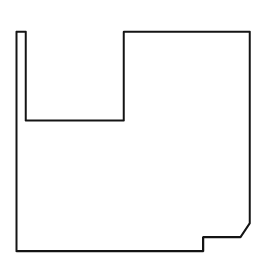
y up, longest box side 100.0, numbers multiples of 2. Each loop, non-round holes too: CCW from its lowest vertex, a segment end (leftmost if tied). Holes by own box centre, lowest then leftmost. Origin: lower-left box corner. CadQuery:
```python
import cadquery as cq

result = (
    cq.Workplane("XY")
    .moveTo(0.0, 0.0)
    .lineTo(80.0, 0.0)
    .lineTo(80.0, 6.0)
    .lineTo(96.0, 6.0)
    .lineTo(100.0, 12.0)
    .lineTo(100.0, 94.0)
    .lineTo(46.0, 94.0)
    .lineTo(46.0, 56.0)
    .lineTo(4.0, 56.0)
    .lineTo(4.0, 94.0)
    .lineTo(0.0, 94.0)
    .close()
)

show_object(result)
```